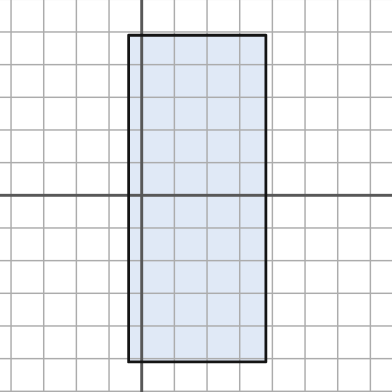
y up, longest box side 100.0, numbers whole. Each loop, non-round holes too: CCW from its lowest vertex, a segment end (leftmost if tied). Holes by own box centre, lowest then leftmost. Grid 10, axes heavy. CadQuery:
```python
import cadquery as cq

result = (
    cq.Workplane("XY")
    .moveTo(-4.0, -51.0)
    .lineTo(38.0, -51.0)
    .lineTo(38.0, 49.0)
    .lineTo(-4.0, 49.0)
    .close()
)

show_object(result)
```